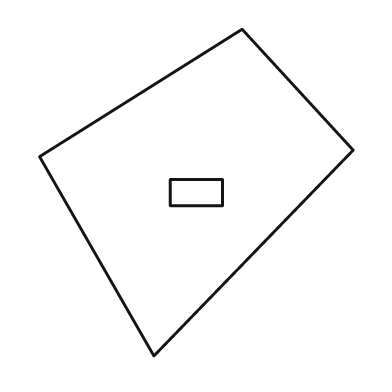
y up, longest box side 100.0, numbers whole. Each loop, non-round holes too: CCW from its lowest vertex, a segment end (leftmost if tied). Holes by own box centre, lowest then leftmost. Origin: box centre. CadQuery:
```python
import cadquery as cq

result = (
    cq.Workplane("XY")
    .moveTo(-13.0, -50.0)
    .lineTo(48.0, 13.0)
    .lineTo(14.0, 50.0)
    .lineTo(-48.0, 11.0)
    .close()
    .moveTo(-8.0, -4.0)
    .lineTo(8.0, -4.0)
    .lineTo(8.0, 4.0)
    .lineTo(-8.0, 4.0)
    .close()
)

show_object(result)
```